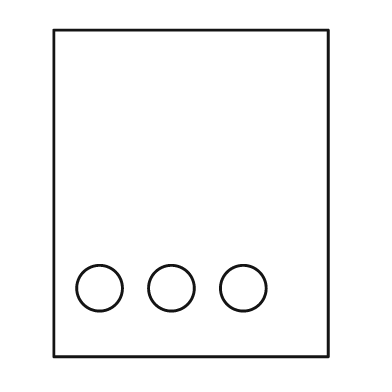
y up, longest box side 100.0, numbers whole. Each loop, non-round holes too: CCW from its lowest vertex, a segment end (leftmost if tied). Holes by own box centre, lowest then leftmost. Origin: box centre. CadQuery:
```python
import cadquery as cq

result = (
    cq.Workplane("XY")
    .moveTo(-42.0, -50.0)
    .lineTo(42.0, -50.0)
    .lineTo(42.0, 50.0)
    .lineTo(-42.0, 50.0)
    .close()
    .moveTo(-28.0, -29.0)
    .circle(7.0)
    .moveTo(-6.0, -29.0)
    .circle(7.0)
    .moveTo(16.0, -29.0)
    .circle(7.0)
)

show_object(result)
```